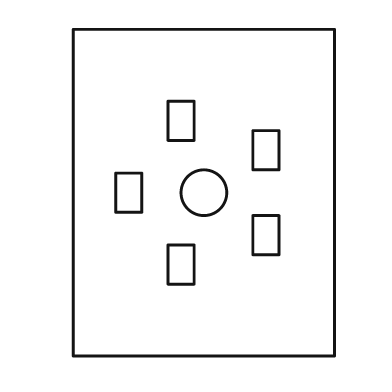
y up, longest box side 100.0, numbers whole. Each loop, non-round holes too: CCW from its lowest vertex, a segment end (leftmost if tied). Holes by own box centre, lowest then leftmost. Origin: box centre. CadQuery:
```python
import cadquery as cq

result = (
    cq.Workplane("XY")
    .moveTo(-40.0, -50.0)
    .lineTo(40.0, -50.0)
    .lineTo(40.0, 50.0)
    .lineTo(-40.0, 50.0)
    .close()
    .moveTo(-11.0, -28.0)
    .lineTo(-3.0, -28.0)
    .lineTo(-3.0, -16.0)
    .lineTo(-11.0, -16.0)
    .close()
    .moveTo(15.0, -19.0)
    .lineTo(23.0, -19.0)
    .lineTo(23.0, -7.0)
    .lineTo(15.0, -7.0)
    .close()
    .moveTo(-27.0, -6.0)
    .lineTo(-19.0, -6.0)
    .lineTo(-19.0, 6.0)
    .lineTo(-27.0, 6.0)
    .close()
    .moveTo(0.0, 0.0)
    .circle(7.0)
    .moveTo(15.0, 7.0)
    .lineTo(23.0, 7.0)
    .lineTo(23.0, 19.0)
    .lineTo(15.0, 19.0)
    .close()
    .moveTo(-11.0, 16.0)
    .lineTo(-3.0, 16.0)
    .lineTo(-3.0, 28.0)
    .lineTo(-11.0, 28.0)
    .close()
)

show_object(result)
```